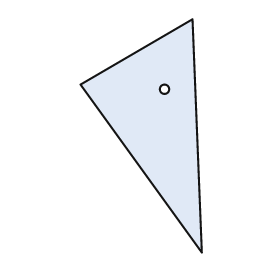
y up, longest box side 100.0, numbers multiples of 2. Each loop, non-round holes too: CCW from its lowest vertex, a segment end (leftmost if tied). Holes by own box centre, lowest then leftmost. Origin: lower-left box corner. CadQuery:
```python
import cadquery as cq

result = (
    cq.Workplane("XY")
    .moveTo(52.0, 0.0)
    .lineTo(48.0, 100.0)
    .lineTo(0.0, 72.0)
    .close()
    .moveTo(36.0, 70.0)
    .circle(2.0)
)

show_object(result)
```